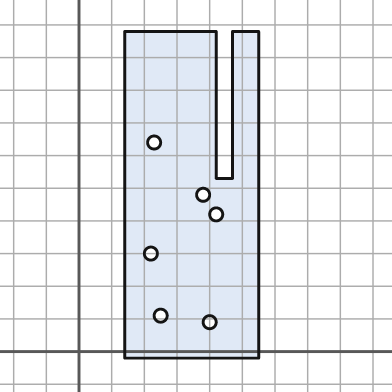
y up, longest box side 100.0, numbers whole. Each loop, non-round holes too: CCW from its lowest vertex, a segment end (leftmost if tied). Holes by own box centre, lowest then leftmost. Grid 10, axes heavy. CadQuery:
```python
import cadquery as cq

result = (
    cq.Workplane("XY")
    .moveTo(14.0, -2.0)
    .lineTo(55.0, -2.0)
    .lineTo(55.0, 98.0)
    .lineTo(47.0, 98.0)
    .lineTo(47.0, 53.0)
    .lineTo(42.0, 53.0)
    .lineTo(42.0, 98.0)
    .lineTo(14.0, 98.0)
    .close()
    .moveTo(40.0, 9.0)
    .circle(2.0)
    .moveTo(25.0, 11.0)
    .circle(2.0)
    .moveTo(22.0, 30.0)
    .circle(2.0)
    .moveTo(42.0, 42.0)
    .circle(2.0)
    .moveTo(38.0, 48.0)
    .circle(2.0)
    .moveTo(23.0, 64.0)
    .circle(2.0)
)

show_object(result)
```